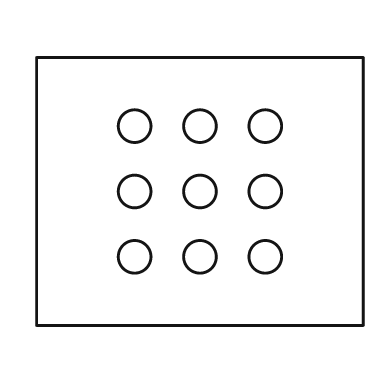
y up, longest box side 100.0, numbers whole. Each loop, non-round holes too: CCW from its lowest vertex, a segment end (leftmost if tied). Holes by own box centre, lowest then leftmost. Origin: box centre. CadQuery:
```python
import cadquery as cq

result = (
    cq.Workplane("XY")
    .moveTo(-50.0, -41.0)
    .lineTo(50.0, -41.0)
    .lineTo(50.0, 41.0)
    .lineTo(-50.0, 41.0)
    .close()
    .moveTo(-20.0, -20.0)
    .circle(5.0)
    .moveTo(0.0, -20.0)
    .circle(5.0)
    .moveTo(20.0, -20.0)
    .circle(5.0)
    .moveTo(-20.0, 0.0)
    .circle(5.0)
    .moveTo(0.0, 0.0)
    .circle(5.0)
    .moveTo(20.0, 0.0)
    .circle(5.0)
    .moveTo(-20.0, 20.0)
    .circle(5.0)
    .moveTo(0.0, 20.0)
    .circle(5.0)
    .moveTo(20.0, 20.0)
    .circle(5.0)
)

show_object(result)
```